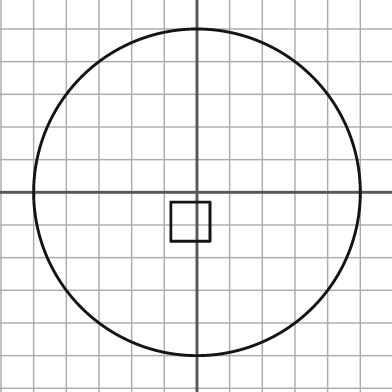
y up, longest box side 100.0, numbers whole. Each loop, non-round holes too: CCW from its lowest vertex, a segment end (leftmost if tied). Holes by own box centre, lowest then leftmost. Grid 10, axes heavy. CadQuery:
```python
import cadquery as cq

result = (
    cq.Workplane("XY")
    .moveTo(0.0, 0.0)
    .circle(50.0)
    .moveTo(-8.0, -15.0)
    .lineTo(4.0, -15.0)
    .lineTo(4.0, -3.0)
    .lineTo(-8.0, -3.0)
    .close()
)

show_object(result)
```